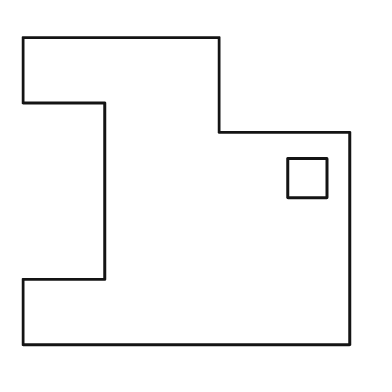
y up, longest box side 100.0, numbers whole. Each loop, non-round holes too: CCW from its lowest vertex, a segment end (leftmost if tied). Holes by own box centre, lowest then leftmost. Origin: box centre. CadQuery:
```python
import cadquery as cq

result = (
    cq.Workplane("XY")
    .moveTo(-50.0, -47.0)
    .lineTo(50.0, -47.0)
    .lineTo(50.0, 18.0)
    .lineTo(10.0, 18.0)
    .lineTo(10.0, 47.0)
    .lineTo(-50.0, 47.0)
    .lineTo(-50.0, 27.0)
    .lineTo(-25.0, 27.0)
    .lineTo(-25.0, -27.0)
    .lineTo(-50.0, -27.0)
    .close()
    .moveTo(31.0, -2.0)
    .lineTo(43.0, -2.0)
    .lineTo(43.0, 10.0)
    .lineTo(31.0, 10.0)
    .close()
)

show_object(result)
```